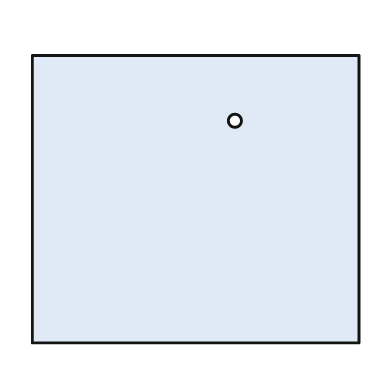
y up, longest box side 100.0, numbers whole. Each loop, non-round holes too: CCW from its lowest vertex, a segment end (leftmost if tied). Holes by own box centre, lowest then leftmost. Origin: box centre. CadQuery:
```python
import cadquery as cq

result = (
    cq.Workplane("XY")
    .moveTo(-50.0, -44.0)
    .lineTo(50.0, -44.0)
    .lineTo(50.0, 44.0)
    .lineTo(-50.0, 44.0)
    .close()
    .moveTo(12.0, 24.0)
    .circle(2.0)
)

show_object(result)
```